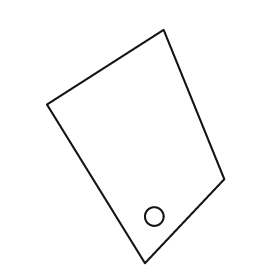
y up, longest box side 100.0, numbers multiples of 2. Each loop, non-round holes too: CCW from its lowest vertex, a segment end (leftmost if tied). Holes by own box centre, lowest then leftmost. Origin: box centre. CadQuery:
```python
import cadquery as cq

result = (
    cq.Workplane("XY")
    .moveTo(4.0, -50.0)
    .lineTo(38.0, -14.0)
    .lineTo(12.0, 50.0)
    .lineTo(-38.0, 18.0)
    .close()
    .moveTo(8.0, -30.0)
    .circle(4.0)
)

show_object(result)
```